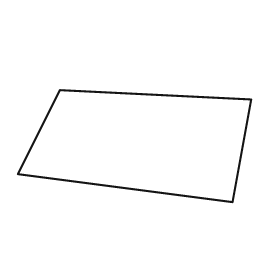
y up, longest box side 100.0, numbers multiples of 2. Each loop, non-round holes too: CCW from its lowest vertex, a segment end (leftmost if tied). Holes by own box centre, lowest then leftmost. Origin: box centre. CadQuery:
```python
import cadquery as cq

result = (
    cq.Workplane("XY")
    .moveTo(42.0, -24.0)
    .lineTo(50.0, 20.0)
    .lineTo(-32.0, 24.0)
    .lineTo(-50.0, -12.0)
    .close()
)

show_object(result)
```